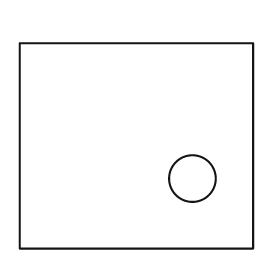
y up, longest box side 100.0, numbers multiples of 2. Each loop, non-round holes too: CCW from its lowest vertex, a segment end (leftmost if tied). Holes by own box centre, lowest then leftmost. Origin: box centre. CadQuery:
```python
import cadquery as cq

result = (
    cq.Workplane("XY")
    .moveTo(-50.0, -44.0)
    .lineTo(50.0, -44.0)
    .lineTo(50.0, 44.0)
    .lineTo(-50.0, 44.0)
    .close()
    .moveTo(24.0, -14.0)
    .circle(10.0)
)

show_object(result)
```